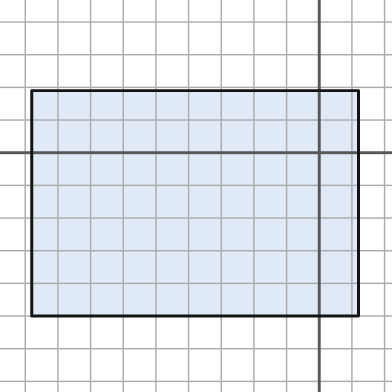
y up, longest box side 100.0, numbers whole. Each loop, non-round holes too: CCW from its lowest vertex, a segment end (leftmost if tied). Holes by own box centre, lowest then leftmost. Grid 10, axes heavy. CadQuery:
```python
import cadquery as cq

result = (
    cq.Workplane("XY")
    .moveTo(-88.0, -50.0)
    .lineTo(12.0, -50.0)
    .lineTo(12.0, 19.0)
    .lineTo(-88.0, 19.0)
    .close()
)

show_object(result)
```